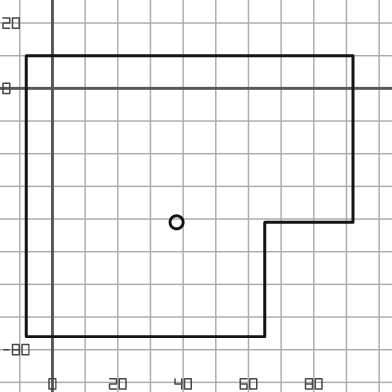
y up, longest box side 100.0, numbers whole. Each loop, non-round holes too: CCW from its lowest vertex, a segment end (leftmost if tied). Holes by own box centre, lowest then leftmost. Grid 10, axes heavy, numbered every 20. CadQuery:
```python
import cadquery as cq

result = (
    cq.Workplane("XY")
    .moveTo(-8.0, -76.0)
    .lineTo(65.0, -76.0)
    .lineTo(65.0, -41.0)
    .lineTo(92.0, -41.0)
    .lineTo(92.0, 10.0)
    .lineTo(-8.0, 10.0)
    .close()
    .moveTo(38.0, -41.0)
    .circle(2.0)
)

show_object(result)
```